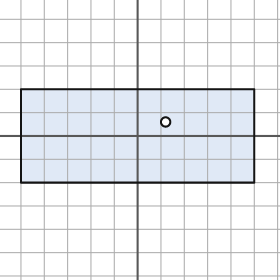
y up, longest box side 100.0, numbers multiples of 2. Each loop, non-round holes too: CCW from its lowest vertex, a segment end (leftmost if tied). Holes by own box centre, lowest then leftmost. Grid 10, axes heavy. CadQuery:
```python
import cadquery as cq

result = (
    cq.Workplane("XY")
    .moveTo(-50.0, -20.0)
    .lineTo(50.0, -20.0)
    .lineTo(50.0, 20.0)
    .lineTo(-50.0, 20.0)
    .close()
    .moveTo(12.0, 6.0)
    .circle(2.0)
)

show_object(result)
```